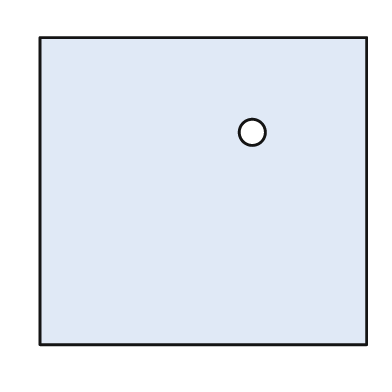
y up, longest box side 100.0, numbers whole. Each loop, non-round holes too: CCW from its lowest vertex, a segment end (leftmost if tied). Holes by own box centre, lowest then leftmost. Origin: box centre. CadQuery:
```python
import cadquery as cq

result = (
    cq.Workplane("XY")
    .moveTo(-50.0, -47.0)
    .lineTo(50.0, -47.0)
    .lineTo(50.0, 47.0)
    .lineTo(-50.0, 47.0)
    .close()
    .moveTo(15.0, 18.0)
    .circle(4.0)
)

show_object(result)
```